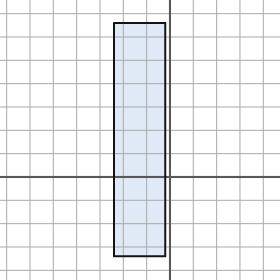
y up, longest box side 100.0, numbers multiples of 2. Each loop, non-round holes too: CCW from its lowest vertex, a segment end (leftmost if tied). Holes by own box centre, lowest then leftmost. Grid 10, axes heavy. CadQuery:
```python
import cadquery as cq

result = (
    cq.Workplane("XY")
    .moveTo(-24.0, -34.0)
    .lineTo(-2.0, -34.0)
    .lineTo(-2.0, 66.0)
    .lineTo(-24.0, 66.0)
    .close()
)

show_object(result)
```